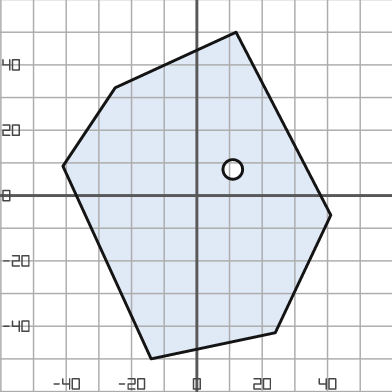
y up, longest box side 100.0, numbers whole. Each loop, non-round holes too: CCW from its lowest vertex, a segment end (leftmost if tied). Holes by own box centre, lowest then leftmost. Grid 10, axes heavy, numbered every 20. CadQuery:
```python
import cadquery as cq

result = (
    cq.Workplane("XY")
    .moveTo(-14.0, -50.0)
    .lineTo(24.0, -42.0)
    .lineTo(41.0, -6.0)
    .lineTo(12.0, 50.0)
    .lineTo(-25.0, 33.0)
    .lineTo(-41.0, 9.0)
    .close()
    .moveTo(11.0, 8.0)
    .circle(3.0)
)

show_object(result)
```